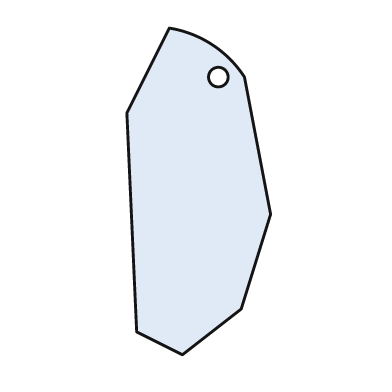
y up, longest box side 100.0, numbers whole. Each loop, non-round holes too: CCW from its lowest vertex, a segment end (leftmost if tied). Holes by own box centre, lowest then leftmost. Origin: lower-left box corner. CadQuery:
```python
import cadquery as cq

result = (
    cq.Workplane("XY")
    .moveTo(17.0, 0.0)
    .lineTo(35.0, 14.0)
    .lineTo(44.0, 43.0)
    .lineTo(36.0, 85.0)
    .threePointArc((26.0, 95.0), (13.0, 100.0))
    .lineTo(0.0, 74.0)
    .lineTo(3.0, 7.0)
    .close()
    .moveTo(28.0, 85.0)
    .circle(3.0)
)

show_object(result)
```